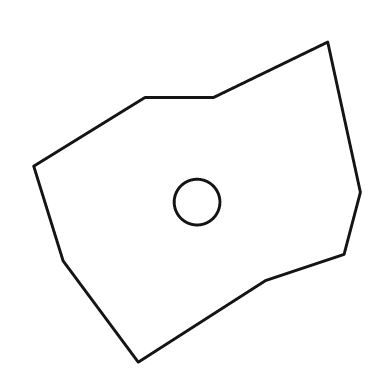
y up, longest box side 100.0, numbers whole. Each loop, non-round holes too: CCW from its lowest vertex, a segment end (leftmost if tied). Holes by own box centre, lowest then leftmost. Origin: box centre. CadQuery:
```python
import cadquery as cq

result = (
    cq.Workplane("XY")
    .moveTo(-18.0, -49.0)
    .lineTo(21.0, -24.0)
    .lineTo(45.0, -16.0)
    .lineTo(50.0, 3.0)
    .lineTo(40.0, 49.0)
    .lineTo(5.0, 32.0)
    .lineTo(-16.0, 32.0)
    .lineTo(-50.0, 11.0)
    .lineTo(-41.0, -18.0)
    .close()
    .moveTo(0.0, 0.0)
    .circle(7.0)
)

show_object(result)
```